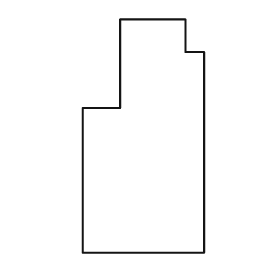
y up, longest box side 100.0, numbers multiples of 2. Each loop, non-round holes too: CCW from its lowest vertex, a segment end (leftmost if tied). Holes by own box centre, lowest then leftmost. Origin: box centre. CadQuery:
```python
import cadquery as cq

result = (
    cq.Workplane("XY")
    .moveTo(-26.0, -50.0)
    .lineTo(26.0, -50.0)
    .lineTo(26.0, 36.0)
    .lineTo(18.0, 36.0)
    .lineTo(18.0, 50.0)
    .lineTo(-10.0, 50.0)
    .lineTo(-10.0, 12.0)
    .lineTo(-26.0, 12.0)
    .close()
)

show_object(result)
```